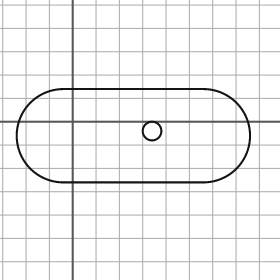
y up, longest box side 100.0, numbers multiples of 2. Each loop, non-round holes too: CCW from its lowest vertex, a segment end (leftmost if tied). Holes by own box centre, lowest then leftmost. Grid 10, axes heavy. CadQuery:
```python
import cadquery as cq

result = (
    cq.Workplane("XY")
    .moveTo(-4.0, -26.0)
    .lineTo(56.0, -26.0)
    .threePointArc((76.0, -6.0), (56.0, 14.0))
    .lineTo(-4.0, 14.0)
    .threePointArc((-24.0, -6.0), (-4.0, -26.0))
    .close()
    .moveTo(34.0, -4.0)
    .circle(4.0)
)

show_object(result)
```